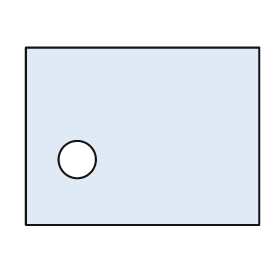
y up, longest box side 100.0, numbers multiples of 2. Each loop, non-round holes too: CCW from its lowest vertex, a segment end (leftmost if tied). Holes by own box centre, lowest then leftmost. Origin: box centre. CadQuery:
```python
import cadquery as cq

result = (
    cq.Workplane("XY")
    .moveTo(-50.0, -38.0)
    .lineTo(50.0, -38.0)
    .lineTo(50.0, 38.0)
    .lineTo(-50.0, 38.0)
    .close()
    .moveTo(-28.0, -10.0)
    .circle(8.0)
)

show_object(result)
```